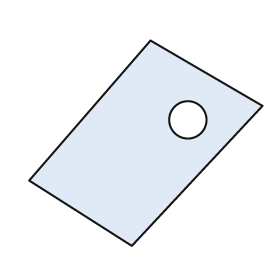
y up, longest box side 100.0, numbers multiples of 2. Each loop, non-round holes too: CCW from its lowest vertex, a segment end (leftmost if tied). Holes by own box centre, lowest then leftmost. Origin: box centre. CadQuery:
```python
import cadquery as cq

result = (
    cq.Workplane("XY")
    .moveTo(-6.0, -44.0)
    .lineTo(50.0, 16.0)
    .lineTo(2.0, 44.0)
    .lineTo(-50.0, -16.0)
    .close()
    .moveTo(18.0, 10.0)
    .circle(8.0)
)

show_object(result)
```